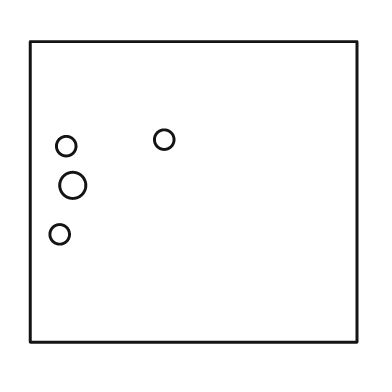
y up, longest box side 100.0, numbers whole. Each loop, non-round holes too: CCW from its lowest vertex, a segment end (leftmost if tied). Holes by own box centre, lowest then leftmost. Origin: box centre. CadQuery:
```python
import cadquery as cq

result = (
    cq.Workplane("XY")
    .moveTo(-50.0, -46.0)
    .lineTo(50.0, -46.0)
    .lineTo(50.0, 46.0)
    .lineTo(-50.0, 46.0)
    .close()
    .moveTo(-41.0, -13.0)
    .circle(3.0)
    .moveTo(-37.0, 2.0)
    .circle(4.0)
    .moveTo(-39.0, 14.0)
    .circle(3.0)
    .moveTo(-9.0, 16.0)
    .circle(3.0)
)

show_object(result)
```